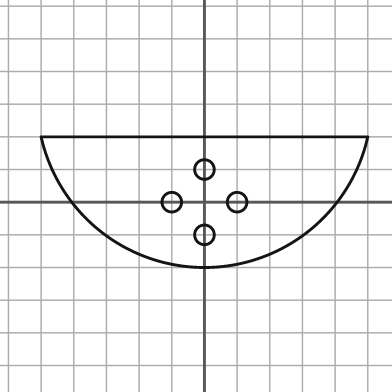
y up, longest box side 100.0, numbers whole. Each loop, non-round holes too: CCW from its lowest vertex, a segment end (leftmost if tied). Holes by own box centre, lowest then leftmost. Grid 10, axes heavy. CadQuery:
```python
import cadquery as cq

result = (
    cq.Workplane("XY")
    .moveTo(-50.0, 20.0)
    .threePointArc((0.0, -20.0), (50.0, 20.0))
    .close()
    .moveTo(0.0, -10.0)
    .circle(3.0)
    .moveTo(-10.0, 0.0)
    .circle(3.0)
    .moveTo(10.0, 0.0)
    .circle(3.0)
    .moveTo(0.0, 10.0)
    .circle(3.0)
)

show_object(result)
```